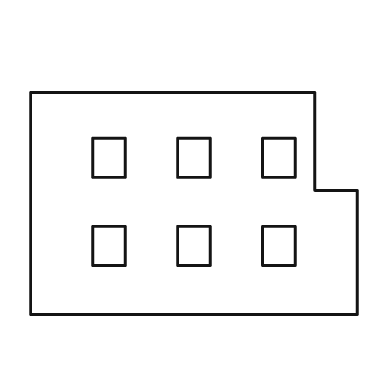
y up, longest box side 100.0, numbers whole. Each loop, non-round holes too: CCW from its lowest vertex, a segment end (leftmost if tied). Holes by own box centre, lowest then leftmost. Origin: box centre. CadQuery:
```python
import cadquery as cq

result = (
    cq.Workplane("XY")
    .moveTo(-50.0, -34.0)
    .lineTo(50.0, -34.0)
    .lineTo(50.0, 4.0)
    .lineTo(37.0, 4.0)
    .lineTo(37.0, 34.0)
    .lineTo(-50.0, 34.0)
    .close()
    .moveTo(-31.0, -19.0)
    .lineTo(-21.0, -19.0)
    .lineTo(-21.0, -7.0)
    .lineTo(-31.0, -7.0)
    .close()
    .moveTo(-5.0, -19.0)
    .lineTo(5.0, -19.0)
    .lineTo(5.0, -7.0)
    .lineTo(-5.0, -7.0)
    .close()
    .moveTo(21.0, -19.0)
    .lineTo(31.0, -19.0)
    .lineTo(31.0, -7.0)
    .lineTo(21.0, -7.0)
    .close()
    .moveTo(-31.0, 8.0)
    .lineTo(-21.0, 8.0)
    .lineTo(-21.0, 20.0)
    .lineTo(-31.0, 20.0)
    .close()
    .moveTo(-5.0, 8.0)
    .lineTo(5.0, 8.0)
    .lineTo(5.0, 20.0)
    .lineTo(-5.0, 20.0)
    .close()
    .moveTo(21.0, 8.0)
    .lineTo(31.0, 8.0)
    .lineTo(31.0, 20.0)
    .lineTo(21.0, 20.0)
    .close()
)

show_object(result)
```